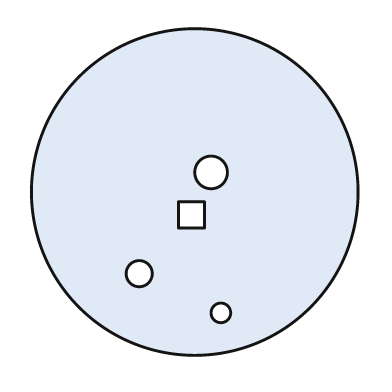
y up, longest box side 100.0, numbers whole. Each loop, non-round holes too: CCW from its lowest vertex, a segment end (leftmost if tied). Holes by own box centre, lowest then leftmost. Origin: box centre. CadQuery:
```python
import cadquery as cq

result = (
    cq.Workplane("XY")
    .moveTo(0.0, 0.0)
    .circle(50.0)
    .moveTo(8.0, -37.0)
    .circle(3.0)
    .moveTo(-17.0, -25.0)
    .circle(4.0)
    .moveTo(-5.0, -11.0)
    .lineTo(3.0, -11.0)
    .lineTo(3.0, -3.0)
    .lineTo(-5.0, -3.0)
    .close()
    .moveTo(5.0, 6.0)
    .circle(5.0)
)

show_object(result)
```